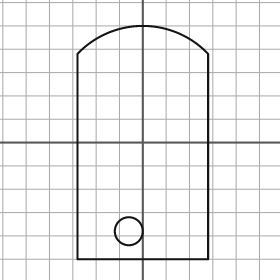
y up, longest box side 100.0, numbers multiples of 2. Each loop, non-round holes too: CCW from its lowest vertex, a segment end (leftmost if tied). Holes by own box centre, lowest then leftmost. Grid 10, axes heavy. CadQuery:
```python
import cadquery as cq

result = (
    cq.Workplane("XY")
    .moveTo(-28.0, -50.0)
    .lineTo(28.0, -50.0)
    .lineTo(28.0, 38.0)
    .threePointArc((0.0, 50.0), (-28.0, 38.0))
    .close()
    .moveTo(-6.0, -38.0)
    .circle(6.0)
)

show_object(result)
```